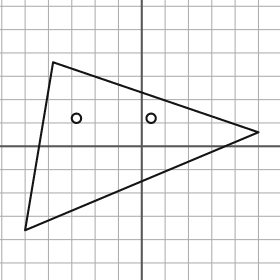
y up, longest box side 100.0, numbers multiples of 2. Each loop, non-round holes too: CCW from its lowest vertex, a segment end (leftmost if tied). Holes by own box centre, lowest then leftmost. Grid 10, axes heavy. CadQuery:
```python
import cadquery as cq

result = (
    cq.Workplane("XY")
    .moveTo(-50.0, -36.0)
    .lineTo(50.0, 6.0)
    .lineTo(-38.0, 36.0)
    .close()
    .moveTo(-28.0, 12.0)
    .circle(2.0)
    .moveTo(4.0, 12.0)
    .circle(2.0)
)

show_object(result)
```